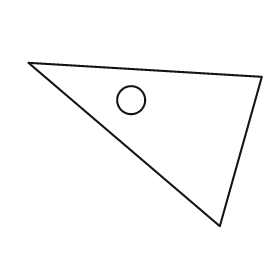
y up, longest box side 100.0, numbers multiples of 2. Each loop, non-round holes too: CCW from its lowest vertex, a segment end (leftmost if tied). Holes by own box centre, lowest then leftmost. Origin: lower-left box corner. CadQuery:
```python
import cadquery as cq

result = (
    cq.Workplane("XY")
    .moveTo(82.0, 0.0)
    .lineTo(100.0, 64.0)
    .lineTo(0.0, 70.0)
    .close()
    .moveTo(44.0, 54.0)
    .circle(6.0)
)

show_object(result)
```